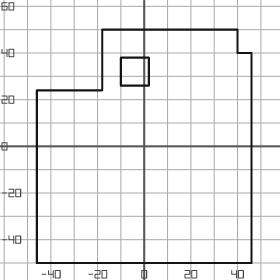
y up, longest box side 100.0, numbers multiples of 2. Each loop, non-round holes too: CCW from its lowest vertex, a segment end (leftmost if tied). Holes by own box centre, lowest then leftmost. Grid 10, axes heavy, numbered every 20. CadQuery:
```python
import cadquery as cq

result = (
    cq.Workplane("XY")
    .moveTo(-46.0, -50.0)
    .lineTo(46.0, -50.0)
    .lineTo(46.0, 40.0)
    .lineTo(40.0, 40.0)
    .lineTo(40.0, 50.0)
    .lineTo(-18.0, 50.0)
    .lineTo(-18.0, 24.0)
    .lineTo(-46.0, 24.0)
    .close()
    .moveTo(-10.0, 26.0)
    .lineTo(2.0, 26.0)
    .lineTo(2.0, 38.0)
    .lineTo(-10.0, 38.0)
    .close()
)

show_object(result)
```